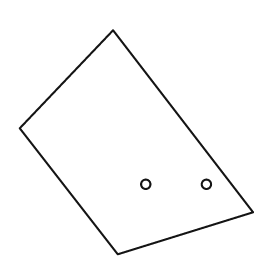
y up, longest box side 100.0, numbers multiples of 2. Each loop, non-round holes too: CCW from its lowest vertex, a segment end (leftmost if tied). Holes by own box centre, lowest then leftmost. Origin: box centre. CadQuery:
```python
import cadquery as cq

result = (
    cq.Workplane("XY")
    .moveTo(-8.0, -48.0)
    .lineTo(50.0, -30.0)
    .lineTo(-10.0, 48.0)
    .lineTo(-50.0, 6.0)
    .close()
    .moveTo(4.0, -18.0)
    .circle(2.0)
    .moveTo(30.0, -18.0)
    .circle(2.0)
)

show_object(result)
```